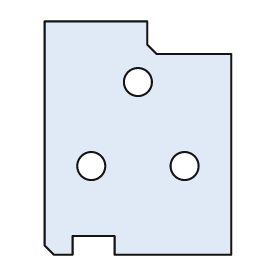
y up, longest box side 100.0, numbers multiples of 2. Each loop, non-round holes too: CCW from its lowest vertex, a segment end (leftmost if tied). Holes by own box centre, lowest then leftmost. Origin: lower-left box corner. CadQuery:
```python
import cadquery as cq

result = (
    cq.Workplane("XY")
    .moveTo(4.0, 0.0)
    .lineTo(12.0, 0.0)
    .lineTo(12.0, 8.0)
    .lineTo(30.0, 8.0)
    .lineTo(30.0, 0.0)
    .lineTo(80.0, 0.0)
    .lineTo(80.0, 86.0)
    .lineTo(48.0, 86.0)
    .lineTo(44.0, 90.0)
    .lineTo(44.0, 100.0)
    .lineTo(0.0, 100.0)
    .lineTo(0.0, 4.0)
    .close()
    .moveTo(20.0, 38.0)
    .circle(6.0)
    .moveTo(60.0, 38.0)
    .circle(6.0)
    .moveTo(40.0, 74.0)
    .circle(6.0)
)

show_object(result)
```